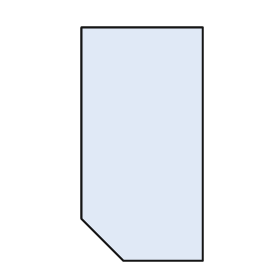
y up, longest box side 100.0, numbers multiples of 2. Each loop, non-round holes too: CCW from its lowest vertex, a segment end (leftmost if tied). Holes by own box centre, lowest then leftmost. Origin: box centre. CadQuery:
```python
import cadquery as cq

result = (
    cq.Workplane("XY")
    .moveTo(-8.0, -50.0)
    .lineTo(26.0, -50.0)
    .lineTo(26.0, 50.0)
    .lineTo(-26.0, 50.0)
    .lineTo(-26.0, -32.0)
    .close()
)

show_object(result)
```